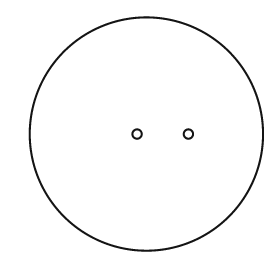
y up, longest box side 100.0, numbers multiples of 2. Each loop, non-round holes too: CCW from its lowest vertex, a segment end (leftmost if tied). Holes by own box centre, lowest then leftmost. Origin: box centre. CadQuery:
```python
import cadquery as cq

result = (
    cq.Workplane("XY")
    .moveTo(0.0, 0.0)
    .circle(50.0)
    .moveTo(-4.0, 0.0)
    .circle(2.0)
    .moveTo(18.0, 0.0)
    .circle(2.0)
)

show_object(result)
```